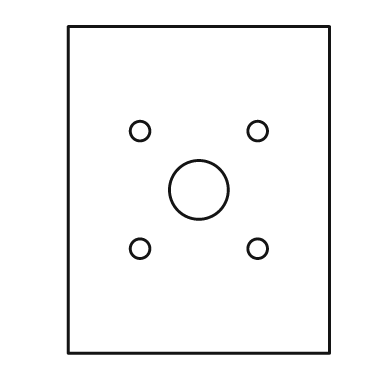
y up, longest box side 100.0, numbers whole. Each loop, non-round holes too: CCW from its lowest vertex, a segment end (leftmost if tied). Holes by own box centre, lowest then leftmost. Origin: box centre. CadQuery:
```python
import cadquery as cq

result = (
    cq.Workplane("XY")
    .moveTo(-40.0, -50.0)
    .lineTo(40.0, -50.0)
    .lineTo(40.0, 50.0)
    .lineTo(-40.0, 50.0)
    .close()
    .moveTo(-18.0, -18.0)
    .circle(3.0)
    .moveTo(18.0, -18.0)
    .circle(3.0)
    .moveTo(0.0, 0.0)
    .circle(9.0)
    .moveTo(-18.0, 18.0)
    .circle(3.0)
    .moveTo(18.0, 18.0)
    .circle(3.0)
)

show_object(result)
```